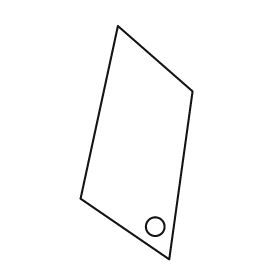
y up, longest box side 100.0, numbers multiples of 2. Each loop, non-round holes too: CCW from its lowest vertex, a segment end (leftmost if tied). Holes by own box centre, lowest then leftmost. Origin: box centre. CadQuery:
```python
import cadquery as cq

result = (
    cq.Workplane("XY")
    .moveTo(14.0, -50.0)
    .lineTo(24.0, 22.0)
    .lineTo(-8.0, 50.0)
    .lineTo(-24.0, -24.0)
    .close()
    .moveTo(8.0, -36.0)
    .circle(4.0)
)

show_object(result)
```